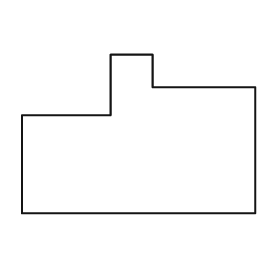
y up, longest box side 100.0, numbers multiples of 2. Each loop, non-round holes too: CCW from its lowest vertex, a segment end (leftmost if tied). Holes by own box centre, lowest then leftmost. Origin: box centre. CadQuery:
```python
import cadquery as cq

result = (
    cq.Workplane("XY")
    .moveTo(-50.0, -34.0)
    .lineTo(50.0, -34.0)
    .lineTo(50.0, 20.0)
    .lineTo(6.0, 20.0)
    .lineTo(6.0, 34.0)
    .lineTo(-12.0, 34.0)
    .lineTo(-12.0, 8.0)
    .lineTo(-50.0, 8.0)
    .close()
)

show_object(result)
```